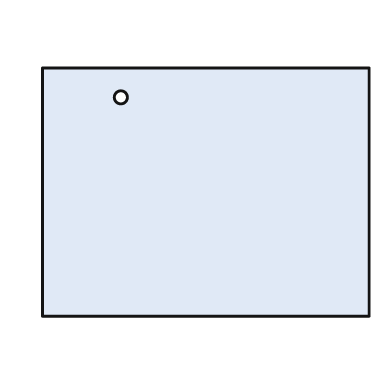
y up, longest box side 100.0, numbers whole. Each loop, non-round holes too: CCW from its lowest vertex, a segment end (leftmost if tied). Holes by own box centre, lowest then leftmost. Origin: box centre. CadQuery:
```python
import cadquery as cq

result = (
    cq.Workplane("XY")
    .moveTo(-50.0, -38.0)
    .lineTo(50.0, -38.0)
    .lineTo(50.0, 38.0)
    .lineTo(-50.0, 38.0)
    .close()
    .moveTo(-26.0, 29.0)
    .circle(2.0)
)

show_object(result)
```